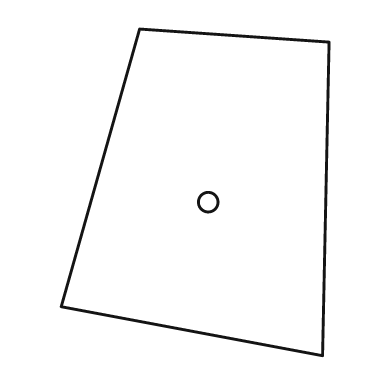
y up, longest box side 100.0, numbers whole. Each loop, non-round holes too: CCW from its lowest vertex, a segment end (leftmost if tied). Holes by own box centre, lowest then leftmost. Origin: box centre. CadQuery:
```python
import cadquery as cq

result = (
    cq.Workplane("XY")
    .moveTo(39.0, -50.0)
    .lineTo(41.0, 46.0)
    .lineTo(-17.0, 50.0)
    .lineTo(-41.0, -35.0)
    .close()
    .moveTo(4.0, -3.0)
    .circle(3.0)
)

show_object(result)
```